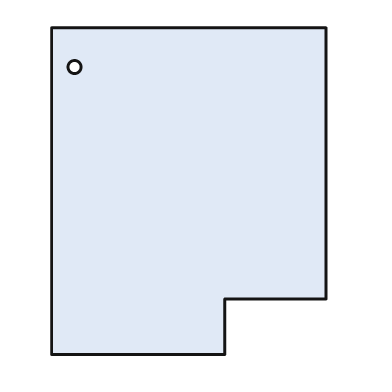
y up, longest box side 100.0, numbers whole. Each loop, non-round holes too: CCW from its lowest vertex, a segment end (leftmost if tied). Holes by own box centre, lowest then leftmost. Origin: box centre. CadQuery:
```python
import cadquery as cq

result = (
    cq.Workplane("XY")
    .moveTo(-42.0, -50.0)
    .lineTo(11.0, -50.0)
    .lineTo(11.0, -33.0)
    .lineTo(42.0, -33.0)
    .lineTo(42.0, 50.0)
    .lineTo(-42.0, 50.0)
    .close()
    .moveTo(-35.0, 38.0)
    .circle(2.0)
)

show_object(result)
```